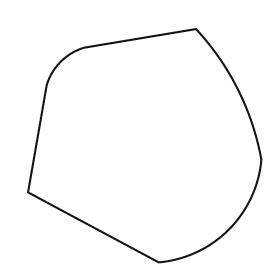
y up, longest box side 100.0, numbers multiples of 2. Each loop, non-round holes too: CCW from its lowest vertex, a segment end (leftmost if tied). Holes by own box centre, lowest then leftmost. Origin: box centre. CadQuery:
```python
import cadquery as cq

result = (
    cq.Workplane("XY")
    .moveTo(6.0, -50.0)
    .threePointArc((36.0, -36.0), (50.0, -6.0))
    .threePointArc((40.0, 24.0), (22.0, 50.0))
    .lineTo(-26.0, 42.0)
    .threePointArc((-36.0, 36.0), (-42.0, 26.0))
    .lineTo(-50.0, -20.0)
    .close()
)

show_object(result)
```